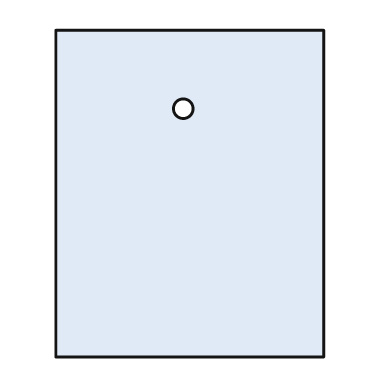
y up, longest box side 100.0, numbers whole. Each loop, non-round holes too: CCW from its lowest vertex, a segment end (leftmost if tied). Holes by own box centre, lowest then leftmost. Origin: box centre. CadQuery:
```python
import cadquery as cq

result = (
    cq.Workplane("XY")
    .moveTo(-41.0, -50.0)
    .lineTo(41.0, -50.0)
    .lineTo(41.0, 50.0)
    .lineTo(-41.0, 50.0)
    .close()
    .moveTo(-2.0, 26.0)
    .circle(3.0)
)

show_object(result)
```